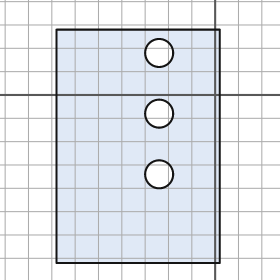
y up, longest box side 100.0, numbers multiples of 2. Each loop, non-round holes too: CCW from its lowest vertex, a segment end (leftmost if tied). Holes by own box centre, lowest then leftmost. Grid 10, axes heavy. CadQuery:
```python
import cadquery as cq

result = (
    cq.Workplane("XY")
    .moveTo(-68.0, -72.0)
    .lineTo(2.0, -72.0)
    .lineTo(2.0, 28.0)
    .lineTo(-68.0, 28.0)
    .close()
    .moveTo(-24.0, -34.0)
    .circle(6.0)
    .moveTo(-24.0, -8.0)
    .circle(6.0)
    .moveTo(-24.0, 18.0)
    .circle(6.0)
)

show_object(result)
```